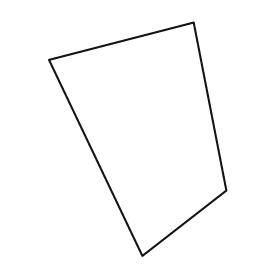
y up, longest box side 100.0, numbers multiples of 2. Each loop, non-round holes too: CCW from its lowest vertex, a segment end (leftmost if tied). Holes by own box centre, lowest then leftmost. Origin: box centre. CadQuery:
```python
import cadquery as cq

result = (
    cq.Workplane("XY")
    .moveTo(2.0, -50.0)
    .lineTo(38.0, -22.0)
    .lineTo(24.0, 50.0)
    .lineTo(-38.0, 34.0)
    .close()
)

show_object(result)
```